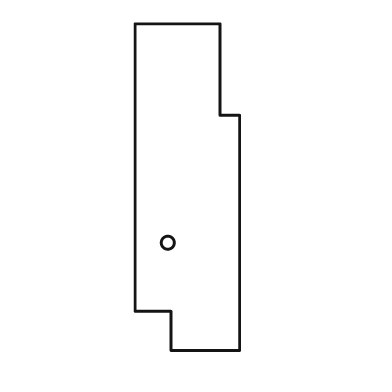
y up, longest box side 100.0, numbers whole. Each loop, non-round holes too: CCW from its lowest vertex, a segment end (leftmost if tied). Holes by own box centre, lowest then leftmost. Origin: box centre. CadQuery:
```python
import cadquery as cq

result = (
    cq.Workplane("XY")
    .moveTo(-5.0, -50.0)
    .lineTo(16.0, -50.0)
    .lineTo(16.0, 22.0)
    .lineTo(10.0, 22.0)
    .lineTo(10.0, 50.0)
    .lineTo(-16.0, 50.0)
    .lineTo(-16.0, -38.0)
    .lineTo(-5.0, -38.0)
    .close()
    .moveTo(-6.0, -17.0)
    .circle(2.0)
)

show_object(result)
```